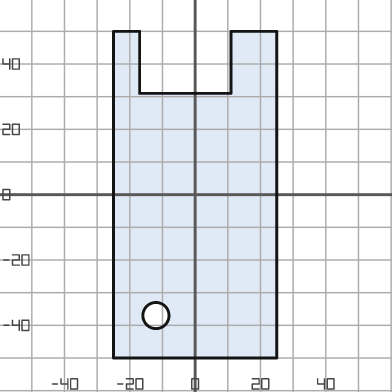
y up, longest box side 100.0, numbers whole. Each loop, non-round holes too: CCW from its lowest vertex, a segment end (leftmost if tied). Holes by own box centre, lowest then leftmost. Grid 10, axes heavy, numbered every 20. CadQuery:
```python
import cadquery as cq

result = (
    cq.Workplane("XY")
    .moveTo(-25.0, -50.0)
    .lineTo(25.0, -50.0)
    .lineTo(25.0, 50.0)
    .lineTo(11.0, 50.0)
    .lineTo(11.0, 31.0)
    .lineTo(-17.0, 31.0)
    .lineTo(-17.0, 50.0)
    .lineTo(-25.0, 50.0)
    .close()
    .moveTo(-12.0, -37.0)
    .circle(4.0)
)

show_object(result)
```